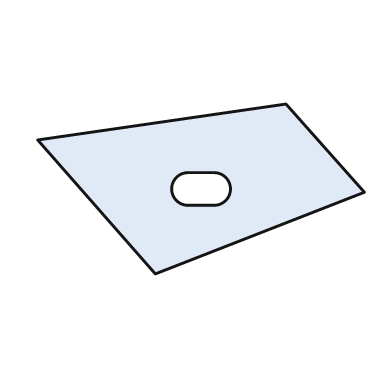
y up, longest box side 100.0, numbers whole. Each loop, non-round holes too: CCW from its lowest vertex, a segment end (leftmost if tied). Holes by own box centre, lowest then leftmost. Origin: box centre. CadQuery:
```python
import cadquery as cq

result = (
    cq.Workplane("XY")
    .moveTo(-14.0, -26.0)
    .lineTo(50.0, -1.0)
    .lineTo(26.0, 26.0)
    .lineTo(-50.0, 15.0)
    .close()
    .moveTo(-4.0, -5.0)
    .lineTo(4.0, -5.0)
    .threePointArc((9.0, 0.0), (4.0, 5.0))
    .lineTo(-4.0, 5.0)
    .threePointArc((-9.0, 0.0), (-4.0, -5.0))
    .close()
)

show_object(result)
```